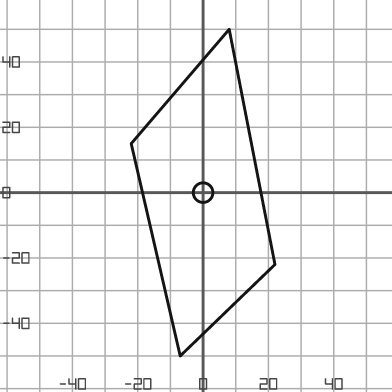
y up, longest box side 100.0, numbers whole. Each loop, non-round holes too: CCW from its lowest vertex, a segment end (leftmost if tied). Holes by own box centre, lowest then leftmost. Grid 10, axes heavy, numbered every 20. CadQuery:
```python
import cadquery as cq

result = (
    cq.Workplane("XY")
    .moveTo(-7.0, -50.0)
    .lineTo(22.0, -22.0)
    .lineTo(8.0, 50.0)
    .lineTo(-22.0, 15.0)
    .close()
    .moveTo(0.0, 0.0)
    .circle(3.0)
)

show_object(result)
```